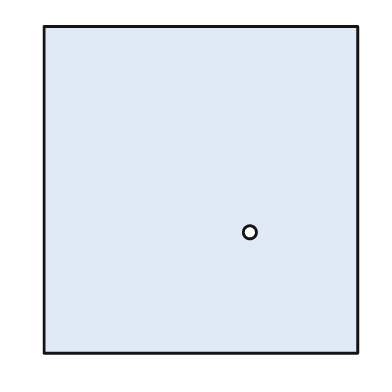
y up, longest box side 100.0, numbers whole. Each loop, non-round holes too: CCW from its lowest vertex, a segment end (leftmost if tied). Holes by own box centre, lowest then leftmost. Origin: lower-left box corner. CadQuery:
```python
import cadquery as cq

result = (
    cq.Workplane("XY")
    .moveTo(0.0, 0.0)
    .lineTo(96.0, 0.0)
    .lineTo(96.0, 100.0)
    .lineTo(0.0, 100.0)
    .close()
    .moveTo(63.0, 37.0)
    .circle(2.0)
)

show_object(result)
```